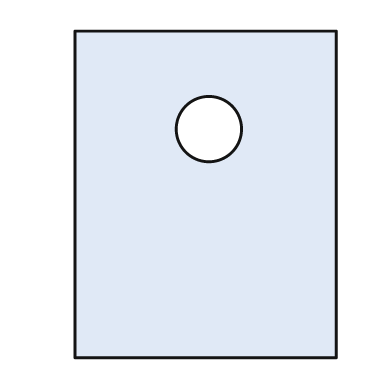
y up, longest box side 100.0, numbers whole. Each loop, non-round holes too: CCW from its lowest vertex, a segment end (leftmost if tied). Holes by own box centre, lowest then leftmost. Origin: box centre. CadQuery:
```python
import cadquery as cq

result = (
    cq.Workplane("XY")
    .moveTo(-40.0, -50.0)
    .lineTo(40.0, -50.0)
    .lineTo(40.0, 50.0)
    .lineTo(-40.0, 50.0)
    .close()
    .moveTo(1.0, 20.0)
    .circle(10.0)
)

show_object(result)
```